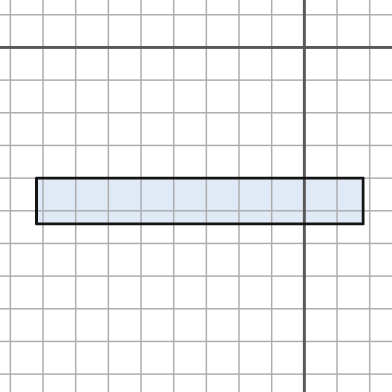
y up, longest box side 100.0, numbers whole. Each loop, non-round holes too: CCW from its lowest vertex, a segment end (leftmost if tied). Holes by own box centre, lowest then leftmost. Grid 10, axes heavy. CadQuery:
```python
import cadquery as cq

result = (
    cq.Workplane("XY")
    .moveTo(-82.0, -54.0)
    .lineTo(18.0, -54.0)
    .lineTo(18.0, -40.0)
    .lineTo(-82.0, -40.0)
    .close()
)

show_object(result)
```